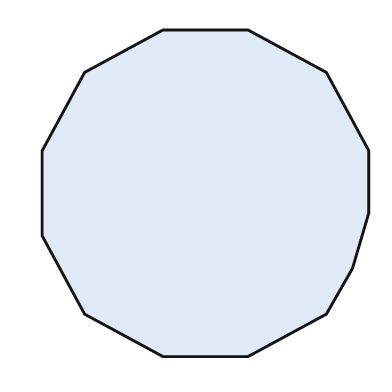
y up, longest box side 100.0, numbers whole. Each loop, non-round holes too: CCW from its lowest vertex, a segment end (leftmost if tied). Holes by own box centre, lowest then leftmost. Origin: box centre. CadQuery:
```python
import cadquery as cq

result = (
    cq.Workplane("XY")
    .moveTo(-13.0, -50.0)
    .lineTo(13.0, -50.0)
    .lineTo(37.0, -37.0)
    .lineTo(45.0, -23.0)
    .lineTo(50.0, -6.0)
    .lineTo(50.0, 13.0)
    .lineTo(37.0, 37.0)
    .lineTo(13.0, 50.0)
    .lineTo(-13.0, 50.0)
    .lineTo(-37.0, 37.0)
    .lineTo(-50.0, 13.0)
    .lineTo(-50.0, -13.0)
    .lineTo(-37.0, -37.0)
    .close()
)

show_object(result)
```